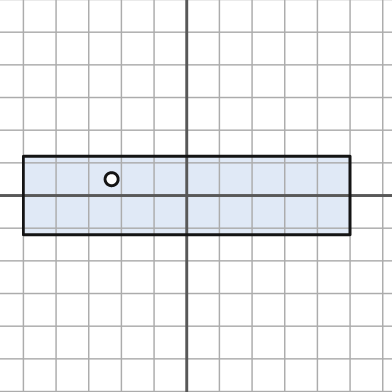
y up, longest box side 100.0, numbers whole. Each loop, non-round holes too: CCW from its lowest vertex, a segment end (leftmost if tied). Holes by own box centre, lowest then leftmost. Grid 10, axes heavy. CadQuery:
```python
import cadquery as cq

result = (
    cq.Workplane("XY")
    .moveTo(-50.0, -12.0)
    .lineTo(50.0, -12.0)
    .lineTo(50.0, 12.0)
    .lineTo(-50.0, 12.0)
    .close()
    .moveTo(-23.0, 5.0)
    .circle(2.0)
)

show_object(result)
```